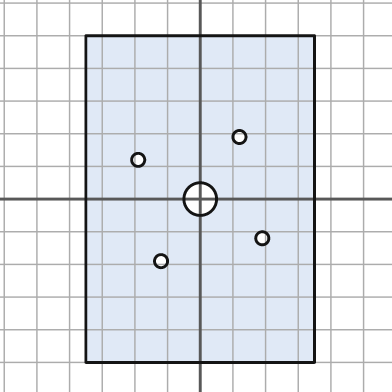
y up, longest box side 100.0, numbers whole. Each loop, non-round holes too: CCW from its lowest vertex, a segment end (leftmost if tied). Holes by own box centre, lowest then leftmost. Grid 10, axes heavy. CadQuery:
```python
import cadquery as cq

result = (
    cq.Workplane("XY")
    .moveTo(-35.0, -50.0)
    .lineTo(35.0, -50.0)
    .lineTo(35.0, 50.0)
    .lineTo(-35.0, 50.0)
    .close()
    .moveTo(-12.0, -19.0)
    .circle(2.0)
    .moveTo(19.0, -12.0)
    .circle(2.0)
    .moveTo(0.0, 0.0)
    .circle(5.0)
    .moveTo(-19.0, 12.0)
    .circle(2.0)
    .moveTo(12.0, 19.0)
    .circle(2.0)
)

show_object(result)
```